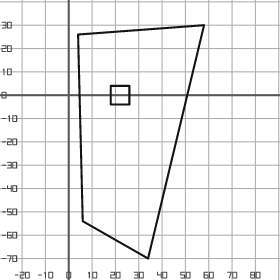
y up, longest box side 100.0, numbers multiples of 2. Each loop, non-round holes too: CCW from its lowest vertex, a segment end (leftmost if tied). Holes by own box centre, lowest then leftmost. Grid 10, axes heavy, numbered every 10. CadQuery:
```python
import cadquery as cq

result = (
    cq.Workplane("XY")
    .moveTo(34.0, -70.0)
    .lineTo(58.0, 30.0)
    .lineTo(4.0, 26.0)
    .lineTo(6.0, -54.0)
    .close()
    .moveTo(18.0, -4.0)
    .lineTo(26.0, -4.0)
    .lineTo(26.0, 4.0)
    .lineTo(18.0, 4.0)
    .close()
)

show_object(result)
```